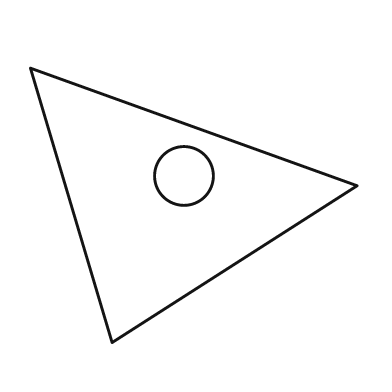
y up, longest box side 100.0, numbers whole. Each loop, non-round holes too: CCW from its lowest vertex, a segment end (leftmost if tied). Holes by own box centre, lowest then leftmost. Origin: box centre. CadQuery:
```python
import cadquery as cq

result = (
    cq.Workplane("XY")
    .moveTo(-25.0, -42.0)
    .lineTo(50.0, 6.0)
    .lineTo(-50.0, 42.0)
    .close()
    .moveTo(-3.0, 9.0)
    .circle(9.0)
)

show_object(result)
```